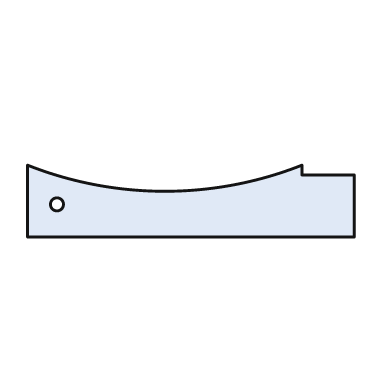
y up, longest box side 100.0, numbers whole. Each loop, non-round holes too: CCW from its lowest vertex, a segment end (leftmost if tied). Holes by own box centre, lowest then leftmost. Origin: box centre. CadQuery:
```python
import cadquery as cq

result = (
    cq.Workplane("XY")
    .moveTo(-50.0, -11.0)
    .lineTo(50.0, -11.0)
    .lineTo(50.0, 8.0)
    .lineTo(34.0, 8.0)
    .lineTo(34.0, 11.0)
    .threePointArc((-8.0, 3.0), (-50.0, 11.0))
    .close()
    .moveTo(-41.0, -1.0)
    .circle(2.0)
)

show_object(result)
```